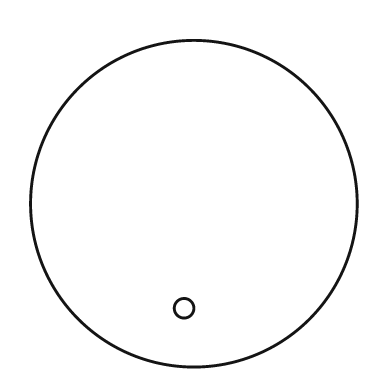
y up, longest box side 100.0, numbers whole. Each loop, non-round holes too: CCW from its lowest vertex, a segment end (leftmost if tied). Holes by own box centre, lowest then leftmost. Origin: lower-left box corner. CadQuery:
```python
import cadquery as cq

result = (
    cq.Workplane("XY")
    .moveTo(50.0, 50.0)
    .circle(50.0)
    .moveTo(47.0, 18.0)
    .circle(3.0)
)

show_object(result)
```